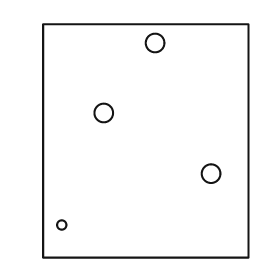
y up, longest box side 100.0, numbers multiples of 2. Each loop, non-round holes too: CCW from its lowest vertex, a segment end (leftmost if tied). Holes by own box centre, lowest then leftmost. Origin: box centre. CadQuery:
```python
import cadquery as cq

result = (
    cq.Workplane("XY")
    .moveTo(-44.0, -50.0)
    .lineTo(44.0, -50.0)
    .lineTo(44.0, 50.0)
    .lineTo(-44.0, 50.0)
    .close()
    .moveTo(-36.0, -36.0)
    .circle(2.0)
    .moveTo(28.0, -14.0)
    .circle(4.0)
    .moveTo(-18.0, 12.0)
    .circle(4.0)
    .moveTo(4.0, 42.0)
    .circle(4.0)
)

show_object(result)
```